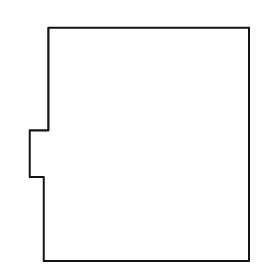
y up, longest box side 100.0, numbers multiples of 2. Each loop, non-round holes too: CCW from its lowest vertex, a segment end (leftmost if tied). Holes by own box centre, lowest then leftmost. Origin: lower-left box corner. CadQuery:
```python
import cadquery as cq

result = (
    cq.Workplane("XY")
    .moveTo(6.0, 0.0)
    .lineTo(94.0, 0.0)
    .lineTo(94.0, 100.0)
    .lineTo(8.0, 100.0)
    .lineTo(8.0, 56.0)
    .lineTo(0.0, 56.0)
    .lineTo(0.0, 36.0)
    .lineTo(6.0, 36.0)
    .close()
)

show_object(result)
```